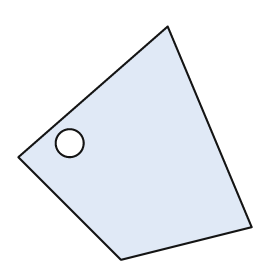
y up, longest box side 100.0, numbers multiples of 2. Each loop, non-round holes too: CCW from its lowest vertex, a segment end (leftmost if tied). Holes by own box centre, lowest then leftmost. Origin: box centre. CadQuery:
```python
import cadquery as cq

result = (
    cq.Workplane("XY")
    .moveTo(-6.0, -50.0)
    .lineTo(50.0, -36.0)
    .lineTo(14.0, 50.0)
    .lineTo(-50.0, -6.0)
    .close()
    .moveTo(-28.0, 0.0)
    .circle(6.0)
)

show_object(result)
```